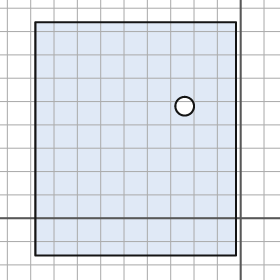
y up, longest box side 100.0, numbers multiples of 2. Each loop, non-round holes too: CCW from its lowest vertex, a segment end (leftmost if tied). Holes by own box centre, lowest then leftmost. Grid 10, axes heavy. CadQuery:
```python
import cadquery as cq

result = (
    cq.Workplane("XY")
    .moveTo(-88.0, -16.0)
    .lineTo(-2.0, -16.0)
    .lineTo(-2.0, 84.0)
    .lineTo(-88.0, 84.0)
    .close()
    .moveTo(-24.0, 48.0)
    .circle(4.0)
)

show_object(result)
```